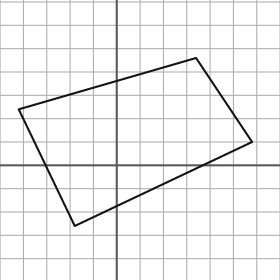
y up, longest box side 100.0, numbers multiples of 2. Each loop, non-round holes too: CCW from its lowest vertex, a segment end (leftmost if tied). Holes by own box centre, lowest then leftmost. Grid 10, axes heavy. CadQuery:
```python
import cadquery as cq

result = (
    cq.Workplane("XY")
    .moveTo(-18.0, -26.0)
    .lineTo(58.0, 10.0)
    .lineTo(34.0, 46.0)
    .lineTo(-42.0, 24.0)
    .close()
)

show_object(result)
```